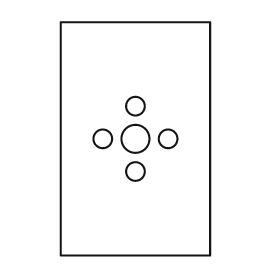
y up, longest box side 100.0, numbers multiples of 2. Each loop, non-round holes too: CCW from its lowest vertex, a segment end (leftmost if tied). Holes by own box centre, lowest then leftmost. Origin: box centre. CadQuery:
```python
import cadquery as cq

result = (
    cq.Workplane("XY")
    .moveTo(-32.0, -50.0)
    .lineTo(32.0, -50.0)
    .lineTo(32.0, 50.0)
    .lineTo(-32.0, 50.0)
    .close()
    .moveTo(0.0, -14.0)
    .circle(4.0)
    .moveTo(-14.0, 0.0)
    .circle(4.0)
    .moveTo(0.0, 0.0)
    .circle(6.0)
    .moveTo(14.0, 0.0)
    .circle(4.0)
    .moveTo(0.0, 14.0)
    .circle(4.0)
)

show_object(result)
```